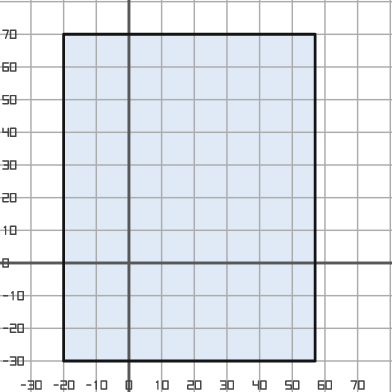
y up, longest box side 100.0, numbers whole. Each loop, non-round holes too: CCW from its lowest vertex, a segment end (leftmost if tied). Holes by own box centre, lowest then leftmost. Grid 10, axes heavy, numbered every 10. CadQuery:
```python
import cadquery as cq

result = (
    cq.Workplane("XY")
    .moveTo(-20.0, -30.0)
    .lineTo(57.0, -30.0)
    .lineTo(57.0, 70.0)
    .lineTo(-20.0, 70.0)
    .close()
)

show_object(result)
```